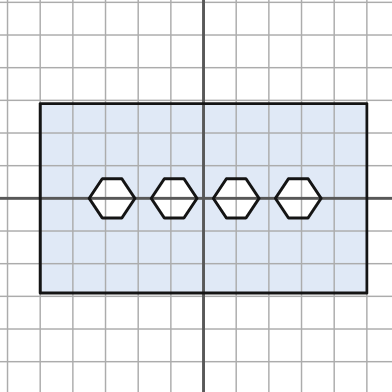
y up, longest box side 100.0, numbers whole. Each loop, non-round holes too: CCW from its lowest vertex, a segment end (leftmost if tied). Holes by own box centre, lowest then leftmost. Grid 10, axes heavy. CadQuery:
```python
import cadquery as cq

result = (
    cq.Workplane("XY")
    .moveTo(-50.0, -29.0)
    .lineTo(50.0, -29.0)
    .lineTo(50.0, 29.0)
    .lineTo(-50.0, 29.0)
    .close()
    .moveTo(-31.0, -6.0)
    .lineTo(-25.0, -6.0)
    .lineTo(-21.0, 0.0)
    .lineTo(-25.0, 6.0)
    .lineTo(-31.0, 6.0)
    .lineTo(-35.0, 0.0)
    .close()
    .moveTo(-12.0, -6.0)
    .lineTo(-6.0, -6.0)
    .lineTo(-2.0, 0.0)
    .lineTo(-6.0, 6.0)
    .lineTo(-12.0, 6.0)
    .lineTo(-16.0, 0.0)
    .close()
    .moveTo(7.0, -6.0)
    .lineTo(13.0, -6.0)
    .lineTo(17.0, 0.0)
    .lineTo(13.0, 6.0)
    .lineTo(7.0, 6.0)
    .lineTo(3.0, 0.0)
    .close()
    .moveTo(26.0, -6.0)
    .lineTo(32.0, -6.0)
    .lineTo(36.0, 0.0)
    .lineTo(32.0, 6.0)
    .lineTo(26.0, 6.0)
    .lineTo(22.0, 0.0)
    .close()
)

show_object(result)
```